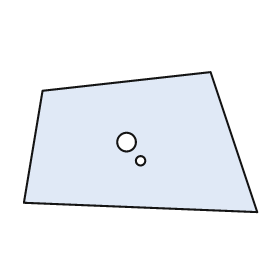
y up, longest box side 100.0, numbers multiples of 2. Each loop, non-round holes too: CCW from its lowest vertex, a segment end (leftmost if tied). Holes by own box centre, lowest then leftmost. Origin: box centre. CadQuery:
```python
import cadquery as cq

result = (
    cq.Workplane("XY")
    .moveTo(50.0, -30.0)
    .lineTo(30.0, 30.0)
    .lineTo(-42.0, 22.0)
    .lineTo(-50.0, -26.0)
    .close()
    .moveTo(0.0, -8.0)
    .circle(2.0)
    .moveTo(-6.0, 0.0)
    .circle(4.0)
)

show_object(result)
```